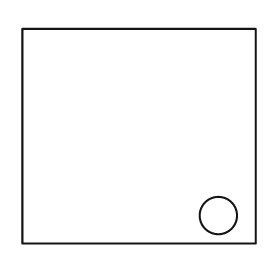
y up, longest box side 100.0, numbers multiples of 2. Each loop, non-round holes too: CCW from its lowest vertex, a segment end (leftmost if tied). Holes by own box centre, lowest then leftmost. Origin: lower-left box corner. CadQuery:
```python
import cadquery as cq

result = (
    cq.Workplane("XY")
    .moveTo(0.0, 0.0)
    .lineTo(100.0, 0.0)
    .lineTo(100.0, 92.0)
    .lineTo(0.0, 92.0)
    .close()
    .moveTo(84.0, 12.0)
    .circle(8.0)
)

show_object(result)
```